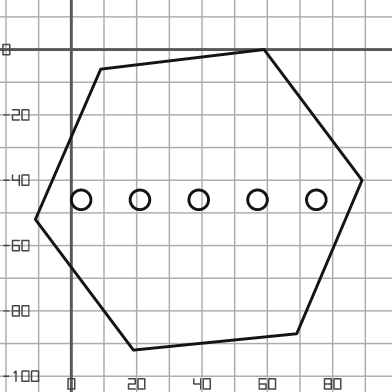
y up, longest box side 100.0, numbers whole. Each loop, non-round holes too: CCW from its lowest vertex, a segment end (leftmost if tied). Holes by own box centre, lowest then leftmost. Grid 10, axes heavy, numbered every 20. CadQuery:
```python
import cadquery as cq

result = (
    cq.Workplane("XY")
    .moveTo(19.0, -92.0)
    .lineTo(69.0, -87.0)
    .lineTo(89.0, -40.0)
    .lineTo(59.0, 0.0)
    .lineTo(9.0, -6.0)
    .lineTo(-11.0, -52.0)
    .close()
    .moveTo(3.0, -46.0)
    .circle(3.0)
    .moveTo(21.0, -46.0)
    .circle(3.0)
    .moveTo(39.0, -46.0)
    .circle(3.0)
    .moveTo(57.0, -46.0)
    .circle(3.0)
    .moveTo(75.0, -46.0)
    .circle(3.0)
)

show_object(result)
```